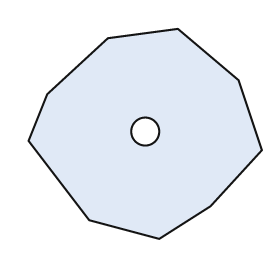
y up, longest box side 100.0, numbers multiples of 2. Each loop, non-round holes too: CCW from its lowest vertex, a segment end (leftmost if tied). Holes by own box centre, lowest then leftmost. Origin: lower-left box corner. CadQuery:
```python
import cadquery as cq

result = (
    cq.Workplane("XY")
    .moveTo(56.0, 0.0)
    .lineTo(78.0, 14.0)
    .lineTo(100.0, 38.0)
    .lineTo(90.0, 68.0)
    .lineTo(64.0, 90.0)
    .lineTo(34.0, 86.0)
    .lineTo(8.0, 62.0)
    .lineTo(0.0, 42.0)
    .lineTo(26.0, 8.0)
    .close()
    .moveTo(50.0, 46.0)
    .circle(6.0)
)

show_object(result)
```